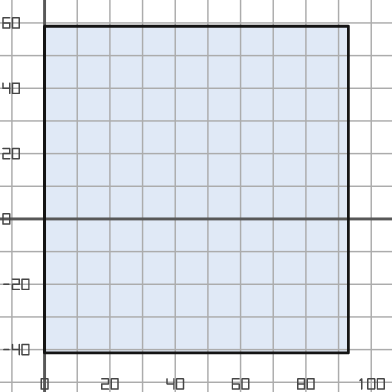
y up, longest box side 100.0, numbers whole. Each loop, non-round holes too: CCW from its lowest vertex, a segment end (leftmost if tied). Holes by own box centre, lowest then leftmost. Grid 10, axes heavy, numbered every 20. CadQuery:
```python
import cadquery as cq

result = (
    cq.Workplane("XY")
    .moveTo(0.0, -41.0)
    .lineTo(93.0, -41.0)
    .lineTo(93.0, 59.0)
    .lineTo(0.0, 59.0)
    .close()
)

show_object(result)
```